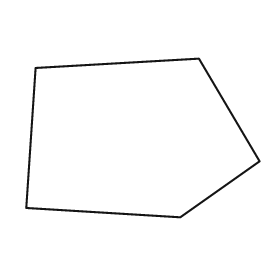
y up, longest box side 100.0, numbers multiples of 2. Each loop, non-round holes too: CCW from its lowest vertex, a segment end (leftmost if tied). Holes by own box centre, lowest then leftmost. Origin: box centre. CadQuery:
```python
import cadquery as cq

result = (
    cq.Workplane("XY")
    .moveTo(16.0, -34.0)
    .lineTo(50.0, -10.0)
    .lineTo(24.0, 34.0)
    .lineTo(-46.0, 30.0)
    .lineTo(-50.0, -30.0)
    .close()
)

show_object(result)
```